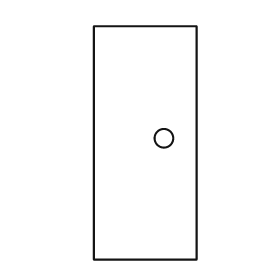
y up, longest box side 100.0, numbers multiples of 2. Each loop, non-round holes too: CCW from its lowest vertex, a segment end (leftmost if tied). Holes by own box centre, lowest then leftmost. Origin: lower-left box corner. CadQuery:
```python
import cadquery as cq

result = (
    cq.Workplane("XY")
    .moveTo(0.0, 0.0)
    .lineTo(44.0, 0.0)
    .lineTo(44.0, 100.0)
    .lineTo(0.0, 100.0)
    .close()
    .moveTo(30.0, 52.0)
    .circle(4.0)
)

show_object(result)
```